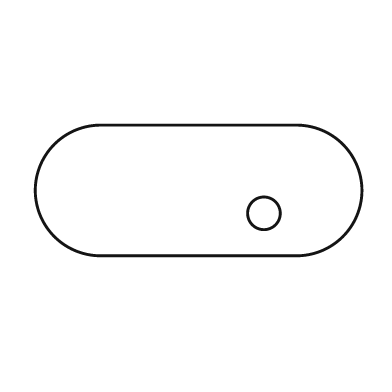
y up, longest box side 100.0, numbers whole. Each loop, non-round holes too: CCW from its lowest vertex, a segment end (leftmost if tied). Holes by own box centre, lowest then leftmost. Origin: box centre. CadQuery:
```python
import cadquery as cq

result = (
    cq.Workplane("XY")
    .moveTo(-30.0, -20.0)
    .lineTo(30.0, -20.0)
    .threePointArc((50.0, 0.0), (30.0, 20.0))
    .lineTo(-30.0, 20.0)
    .threePointArc((-50.0, 0.0), (-30.0, -20.0))
    .close()
    .moveTo(20.0, -7.0)
    .circle(5.0)
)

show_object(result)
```